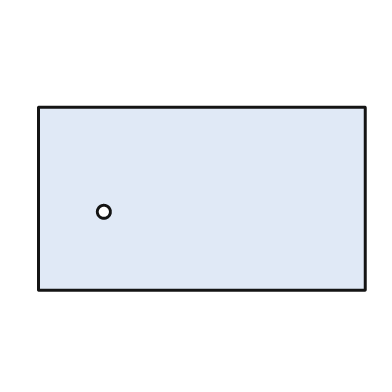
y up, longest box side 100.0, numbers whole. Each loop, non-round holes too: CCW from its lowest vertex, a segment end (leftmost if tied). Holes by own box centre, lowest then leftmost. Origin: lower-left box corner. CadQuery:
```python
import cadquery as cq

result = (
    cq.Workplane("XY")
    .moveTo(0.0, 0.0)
    .lineTo(100.0, 0.0)
    .lineTo(100.0, 56.0)
    .lineTo(0.0, 56.0)
    .close()
    .moveTo(20.0, 24.0)
    .circle(2.0)
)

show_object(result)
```